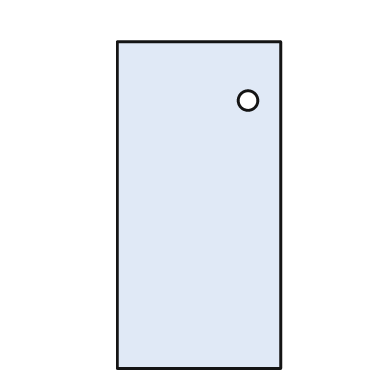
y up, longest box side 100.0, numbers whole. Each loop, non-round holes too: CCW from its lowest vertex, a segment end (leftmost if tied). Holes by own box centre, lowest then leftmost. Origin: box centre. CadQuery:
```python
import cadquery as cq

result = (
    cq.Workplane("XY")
    .moveTo(-25.0, -50.0)
    .lineTo(25.0, -50.0)
    .lineTo(25.0, 50.0)
    .lineTo(-25.0, 50.0)
    .close()
    .moveTo(15.0, 32.0)
    .circle(3.0)
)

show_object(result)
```